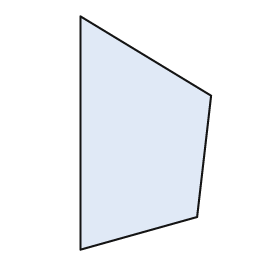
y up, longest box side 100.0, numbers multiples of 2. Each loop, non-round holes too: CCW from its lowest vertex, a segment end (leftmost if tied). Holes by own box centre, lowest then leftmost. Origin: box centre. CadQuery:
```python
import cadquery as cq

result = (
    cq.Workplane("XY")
    .moveTo(-28.0, -50.0)
    .lineTo(22.0, -36.0)
    .lineTo(28.0, 16.0)
    .lineTo(-28.0, 50.0)
    .close()
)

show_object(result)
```